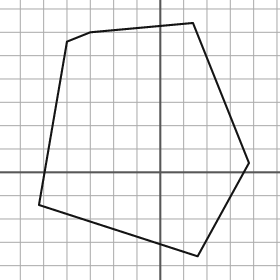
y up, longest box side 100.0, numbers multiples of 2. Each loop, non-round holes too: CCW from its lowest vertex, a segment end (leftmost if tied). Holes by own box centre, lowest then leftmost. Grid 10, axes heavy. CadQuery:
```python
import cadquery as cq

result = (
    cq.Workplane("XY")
    .moveTo(16.0, -36.0)
    .lineTo(38.0, 4.0)
    .lineTo(14.0, 64.0)
    .lineTo(-30.0, 60.0)
    .lineTo(-40.0, 56.0)
    .lineTo(-52.0, -14.0)
    .close()
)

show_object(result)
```